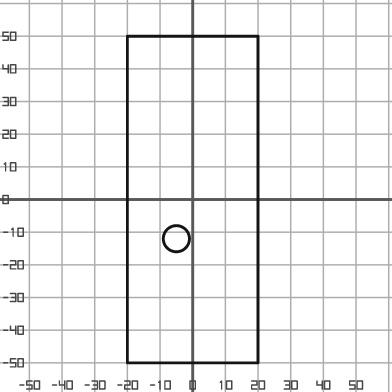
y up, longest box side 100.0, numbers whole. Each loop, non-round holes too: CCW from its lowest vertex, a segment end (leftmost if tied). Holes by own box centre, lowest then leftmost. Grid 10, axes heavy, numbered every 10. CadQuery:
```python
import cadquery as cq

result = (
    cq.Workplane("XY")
    .moveTo(-20.0, -50.0)
    .lineTo(20.0, -50.0)
    .lineTo(20.0, 50.0)
    .lineTo(-20.0, 50.0)
    .close()
    .moveTo(-5.0, -12.0)
    .circle(4.0)
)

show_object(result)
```